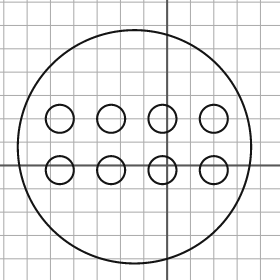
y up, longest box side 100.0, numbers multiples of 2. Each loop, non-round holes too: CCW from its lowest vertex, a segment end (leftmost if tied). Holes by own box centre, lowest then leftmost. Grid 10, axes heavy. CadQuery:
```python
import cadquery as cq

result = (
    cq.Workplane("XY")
    .moveTo(-14.0, 8.0)
    .circle(50.0)
    .moveTo(-46.0, -2.0)
    .circle(6.0)
    .moveTo(-24.0, -2.0)
    .circle(6.0)
    .moveTo(-2.0, -2.0)
    .circle(6.0)
    .moveTo(20.0, -2.0)
    .circle(6.0)
    .moveTo(-46.0, 20.0)
    .circle(6.0)
    .moveTo(-24.0, 20.0)
    .circle(6.0)
    .moveTo(-2.0, 20.0)
    .circle(6.0)
    .moveTo(20.0, 20.0)
    .circle(6.0)
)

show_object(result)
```